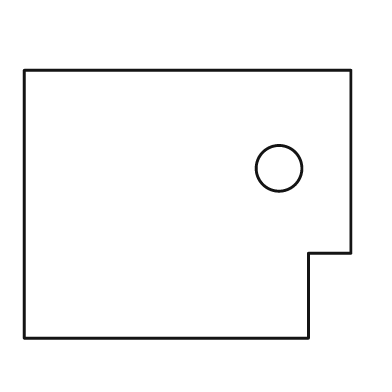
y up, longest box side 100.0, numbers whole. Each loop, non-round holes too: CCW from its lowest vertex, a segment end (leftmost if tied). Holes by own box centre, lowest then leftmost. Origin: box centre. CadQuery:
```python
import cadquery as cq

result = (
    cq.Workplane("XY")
    .moveTo(-50.0, -41.0)
    .lineTo(37.0, -41.0)
    .lineTo(37.0, -15.0)
    .lineTo(50.0, -15.0)
    .lineTo(50.0, 41.0)
    .lineTo(-50.0, 41.0)
    .close()
    .moveTo(28.0, 11.0)
    .circle(7.0)
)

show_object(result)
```